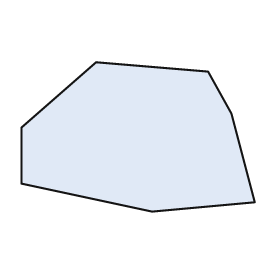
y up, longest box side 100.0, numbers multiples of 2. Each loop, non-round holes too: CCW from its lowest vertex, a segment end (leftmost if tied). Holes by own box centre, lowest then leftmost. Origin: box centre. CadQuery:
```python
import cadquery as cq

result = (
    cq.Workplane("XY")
    .moveTo(6.0, -32.0)
    .lineTo(50.0, -28.0)
    .lineTo(40.0, 10.0)
    .lineTo(30.0, 28.0)
    .lineTo(-18.0, 32.0)
    .lineTo(-50.0, 4.0)
    .lineTo(-50.0, -20.0)
    .close()
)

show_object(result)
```